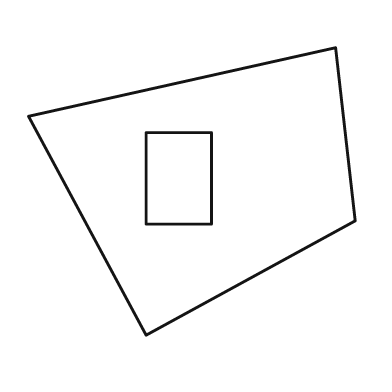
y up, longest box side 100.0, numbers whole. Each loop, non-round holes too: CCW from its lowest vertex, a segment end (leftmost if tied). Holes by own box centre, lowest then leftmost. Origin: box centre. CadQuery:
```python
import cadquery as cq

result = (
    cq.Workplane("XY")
    .moveTo(-14.0, -44.0)
    .lineTo(50.0, -9.0)
    .lineTo(44.0, 44.0)
    .lineTo(-50.0, 23.0)
    .close()
    .moveTo(-14.0, -10.0)
    .lineTo(6.0, -10.0)
    .lineTo(6.0, 18.0)
    .lineTo(-14.0, 18.0)
    .close()
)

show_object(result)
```